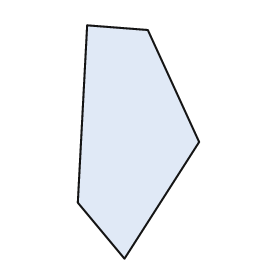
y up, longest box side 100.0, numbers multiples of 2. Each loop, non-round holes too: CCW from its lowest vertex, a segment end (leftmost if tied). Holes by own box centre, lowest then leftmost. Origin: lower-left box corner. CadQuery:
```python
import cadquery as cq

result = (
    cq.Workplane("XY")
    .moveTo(20.0, 0.0)
    .lineTo(52.0, 50.0)
    .lineTo(30.0, 98.0)
    .lineTo(4.0, 100.0)
    .lineTo(0.0, 24.0)
    .close()
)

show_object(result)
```